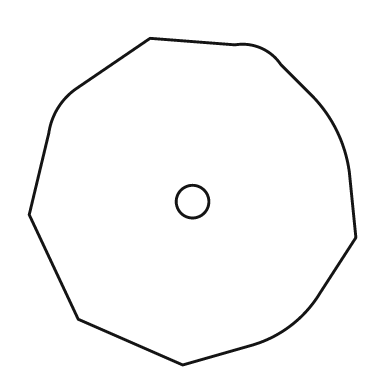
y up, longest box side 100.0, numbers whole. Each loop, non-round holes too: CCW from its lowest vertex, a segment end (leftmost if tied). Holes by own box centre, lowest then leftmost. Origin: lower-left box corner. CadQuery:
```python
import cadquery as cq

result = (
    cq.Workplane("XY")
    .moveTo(47.0, 0.0)
    .lineTo(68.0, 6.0)
    .threePointArc((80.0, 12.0), (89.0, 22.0))
    .lineTo(100.0, 39.0)
    .lineTo(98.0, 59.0)
    .threePointArc((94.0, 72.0), (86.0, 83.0))
    .lineTo(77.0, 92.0)
    .threePointArc((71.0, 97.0), (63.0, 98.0))
    .lineTo(37.0, 100.0)
    .lineTo(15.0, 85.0)
    .threePointArc((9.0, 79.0), (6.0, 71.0))
    .lineTo(0.0, 46.0)
    .lineTo(15.0, 14.0)
    .close()
    .moveTo(50.0, 50.0)
    .circle(5.0)
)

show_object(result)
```